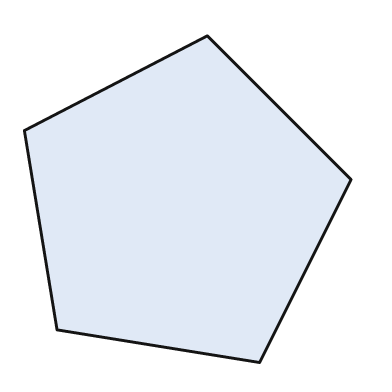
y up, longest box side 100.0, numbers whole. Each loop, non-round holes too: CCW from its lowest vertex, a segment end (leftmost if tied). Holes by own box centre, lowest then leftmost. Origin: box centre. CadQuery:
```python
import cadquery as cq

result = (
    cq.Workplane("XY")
    .moveTo(22.0, -50.0)
    .lineTo(50.0, 6.0)
    .lineTo(6.0, 50.0)
    .lineTo(-50.0, 21.0)
    .lineTo(-40.0, -40.0)
    .close()
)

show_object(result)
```